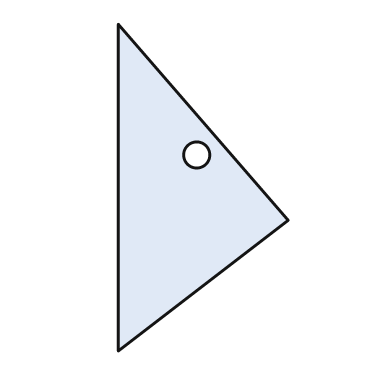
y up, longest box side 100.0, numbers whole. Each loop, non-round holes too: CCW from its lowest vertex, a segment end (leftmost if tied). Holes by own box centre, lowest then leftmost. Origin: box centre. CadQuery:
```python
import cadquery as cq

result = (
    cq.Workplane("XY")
    .moveTo(-26.0, -50.0)
    .lineTo(26.0, -10.0)
    .lineTo(-26.0, 50.0)
    .close()
    .moveTo(-2.0, 10.0)
    .circle(4.0)
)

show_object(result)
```